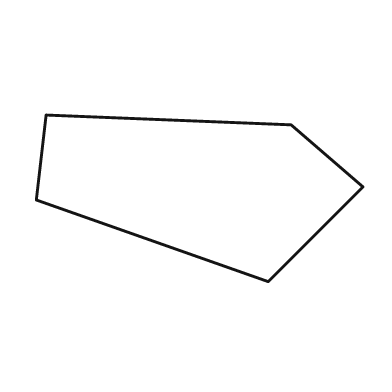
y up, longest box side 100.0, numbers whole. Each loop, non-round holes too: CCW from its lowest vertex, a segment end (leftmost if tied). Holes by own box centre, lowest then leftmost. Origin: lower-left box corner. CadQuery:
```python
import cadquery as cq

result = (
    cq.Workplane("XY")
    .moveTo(71.0, 0.0)
    .lineTo(100.0, 29.0)
    .lineTo(78.0, 48.0)
    .lineTo(3.0, 51.0)
    .lineTo(0.0, 25.0)
    .close()
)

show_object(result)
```